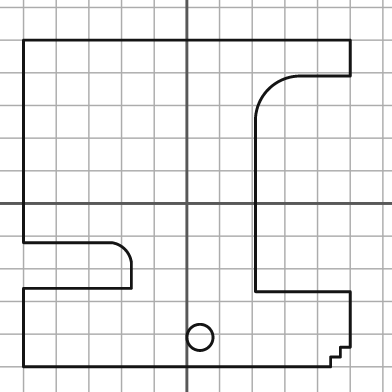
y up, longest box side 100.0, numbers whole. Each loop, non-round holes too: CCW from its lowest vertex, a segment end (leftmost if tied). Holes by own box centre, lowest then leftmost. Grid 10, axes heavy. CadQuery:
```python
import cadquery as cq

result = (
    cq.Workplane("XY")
    .moveTo(-50.0, -50.0)
    .lineTo(44.0, -50.0)
    .lineTo(44.0, -47.0)
    .lineTo(47.0, -47.0)
    .lineTo(47.0, -44.0)
    .lineTo(50.0, -44.0)
    .lineTo(50.0, -27.0)
    .lineTo(21.0, -27.0)
    .lineTo(21.0, 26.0)
    .threePointArc((25.0, 35.0), (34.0, 39.0))
    .lineTo(50.0, 39.0)
    .lineTo(50.0, 50.0)
    .lineTo(-50.0, 50.0)
    .lineTo(-50.0, -12.0)
    .lineTo(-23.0, -12.0)
    .threePointArc((-19.0, -14.0), (-17.0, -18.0))
    .lineTo(-17.0, -26.0)
    .lineTo(-50.0, -26.0)
    .close()
    .moveTo(4.0, -41.0)
    .circle(4.0)
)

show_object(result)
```